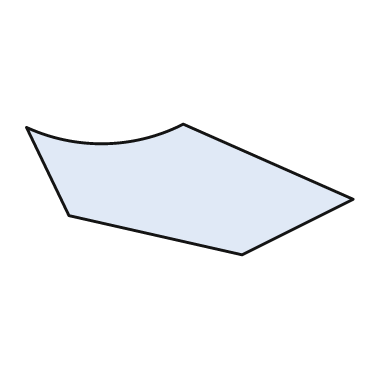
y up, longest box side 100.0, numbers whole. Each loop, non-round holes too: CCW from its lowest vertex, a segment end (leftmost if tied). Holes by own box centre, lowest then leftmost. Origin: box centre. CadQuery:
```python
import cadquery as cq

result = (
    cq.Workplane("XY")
    .moveTo(16.0, -20.0)
    .lineTo(50.0, -3.0)
    .lineTo(-2.0, 20.0)
    .threePointArc((-26.0, 14.0), (-50.0, 19.0))
    .lineTo(-37.0, -8.0)
    .close()
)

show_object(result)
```